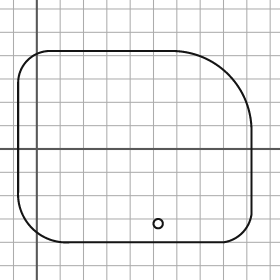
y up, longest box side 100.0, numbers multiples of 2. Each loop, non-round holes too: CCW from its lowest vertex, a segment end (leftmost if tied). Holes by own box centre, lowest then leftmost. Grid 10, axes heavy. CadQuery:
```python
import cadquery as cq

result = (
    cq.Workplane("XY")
    .moveTo(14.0, -40.0)
    .lineTo(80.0, -40.0)
    .threePointArc((88.0, -36.0), (92.0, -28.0))
    .lineTo(92.0, 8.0)
    .threePointArc((82.0, 32.0), (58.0, 42.0))
    .lineTo(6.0, 42.0)
    .threePointArc((-4.0, 38.0), (-8.0, 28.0))
    .lineTo(-8.0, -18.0)
    .threePointArc((-2.0, -34.0), (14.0, -40.0))
    .close()
    .moveTo(52.0, -32.0)
    .circle(2.0)
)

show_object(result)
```